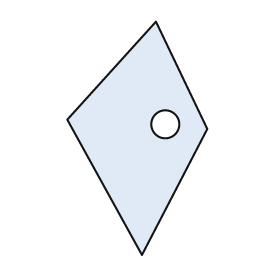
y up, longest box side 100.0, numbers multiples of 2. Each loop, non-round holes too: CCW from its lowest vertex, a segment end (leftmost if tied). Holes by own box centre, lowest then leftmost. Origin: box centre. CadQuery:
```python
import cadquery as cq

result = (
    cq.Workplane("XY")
    .moveTo(2.0, -50.0)
    .lineTo(30.0, 4.0)
    .lineTo(8.0, 50.0)
    .lineTo(-30.0, 8.0)
    .close()
    .moveTo(12.0, 6.0)
    .circle(6.0)
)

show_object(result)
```